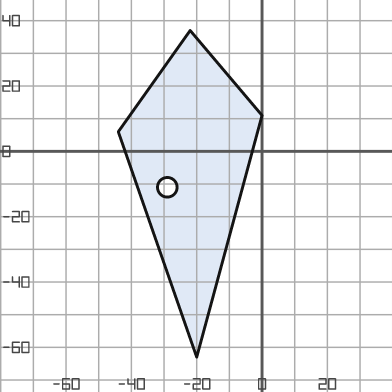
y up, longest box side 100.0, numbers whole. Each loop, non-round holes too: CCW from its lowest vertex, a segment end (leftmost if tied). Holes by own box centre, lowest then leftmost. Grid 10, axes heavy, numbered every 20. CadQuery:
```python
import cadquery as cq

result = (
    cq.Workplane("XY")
    .moveTo(-20.0, -63.0)
    .lineTo(0.0, 11.0)
    .lineTo(-22.0, 37.0)
    .lineTo(-44.0, 6.0)
    .close()
    .moveTo(-29.0, -11.0)
    .circle(3.0)
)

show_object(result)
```